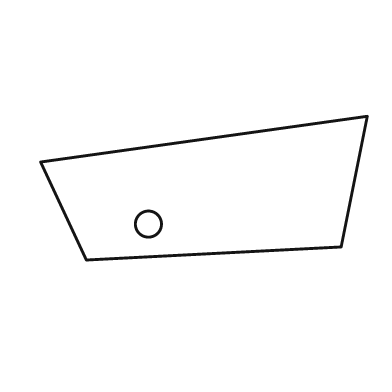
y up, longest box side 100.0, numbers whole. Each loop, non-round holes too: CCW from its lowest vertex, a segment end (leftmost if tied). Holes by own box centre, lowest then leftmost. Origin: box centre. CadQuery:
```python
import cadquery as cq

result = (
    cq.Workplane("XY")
    .moveTo(-36.0, -22.0)
    .lineTo(42.0, -18.0)
    .lineTo(50.0, 22.0)
    .lineTo(-50.0, 8.0)
    .close()
    .moveTo(-17.0, -11.0)
    .circle(4.0)
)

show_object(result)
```